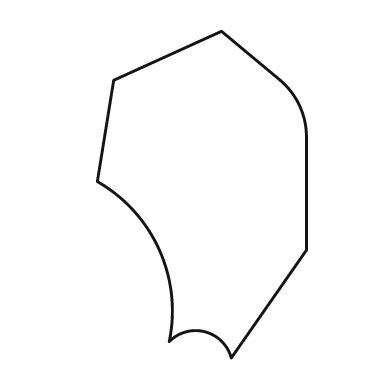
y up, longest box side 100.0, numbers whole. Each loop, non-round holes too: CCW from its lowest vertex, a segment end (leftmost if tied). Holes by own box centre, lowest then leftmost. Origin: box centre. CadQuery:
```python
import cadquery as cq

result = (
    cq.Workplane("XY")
    .moveTo(9.0, -50.0)
    .lineTo(32.0, -17.0)
    .lineTo(32.0, 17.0)
    .threePointArc((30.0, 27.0), (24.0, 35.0))
    .lineTo(6.0, 50.0)
    .lineTo(-27.0, 35.0)
    .lineTo(-32.0, 4.0)
    .threePointArc((-13.0, -17.0), (-10.0, -45.0))
    .threePointArc((1.0, -42.0), (9.0, -50.0))
    .close()
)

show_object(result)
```